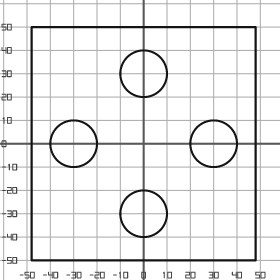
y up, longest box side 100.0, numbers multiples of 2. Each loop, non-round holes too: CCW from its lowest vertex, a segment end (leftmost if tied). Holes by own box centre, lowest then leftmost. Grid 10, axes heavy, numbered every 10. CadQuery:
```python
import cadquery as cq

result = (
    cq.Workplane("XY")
    .moveTo(-48.0, -50.0)
    .lineTo(48.0, -50.0)
    .lineTo(48.0, 50.0)
    .lineTo(-48.0, 50.0)
    .close()
    .moveTo(0.0, -30.0)
    .circle(10.0)
    .moveTo(-30.0, 0.0)
    .circle(10.0)
    .moveTo(30.0, 0.0)
    .circle(10.0)
    .moveTo(0.0, 30.0)
    .circle(10.0)
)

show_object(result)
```